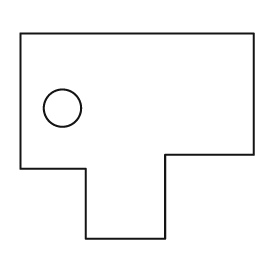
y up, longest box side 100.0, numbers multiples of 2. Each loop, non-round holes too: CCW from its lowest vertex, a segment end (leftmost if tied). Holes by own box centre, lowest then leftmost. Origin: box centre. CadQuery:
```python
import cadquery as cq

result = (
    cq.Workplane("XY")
    .moveTo(-22.0, -44.0)
    .lineTo(12.0, -44.0)
    .lineTo(12.0, -8.0)
    .lineTo(50.0, -8.0)
    .lineTo(50.0, 44.0)
    .lineTo(-50.0, 44.0)
    .lineTo(-50.0, -14.0)
    .lineTo(-22.0, -14.0)
    .close()
    .moveTo(-32.0, 12.0)
    .circle(8.0)
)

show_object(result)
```